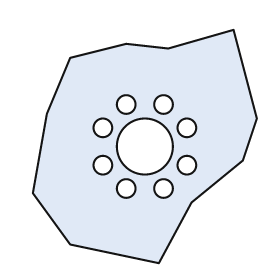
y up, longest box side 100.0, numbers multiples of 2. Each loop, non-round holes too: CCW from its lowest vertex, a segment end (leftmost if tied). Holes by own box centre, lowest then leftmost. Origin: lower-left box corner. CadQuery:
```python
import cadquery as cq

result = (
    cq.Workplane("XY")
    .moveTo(54.0, 0.0)
    .lineTo(68.0, 26.0)
    .lineTo(90.0, 44.0)
    .lineTo(96.0, 62.0)
    .lineTo(86.0, 100.0)
    .lineTo(58.0, 92.0)
    .lineTo(40.0, 94.0)
    .lineTo(16.0, 88.0)
    .lineTo(6.0, 64.0)
    .lineTo(0.0, 30.0)
    .lineTo(16.0, 8.0)
    .close()
    .moveTo(40.0, 32.0)
    .circle(4.0)
    .moveTo(56.0, 32.0)
    .circle(4.0)
    .moveTo(30.0, 42.0)
    .circle(4.0)
    .moveTo(66.0, 42.0)
    .circle(4.0)
    .moveTo(48.0, 50.0)
    .circle(12.0)
    .moveTo(30.0, 58.0)
    .circle(4.0)
    .moveTo(66.0, 58.0)
    .circle(4.0)
    .moveTo(40.0, 68.0)
    .circle(4.0)
    .moveTo(56.0, 68.0)
    .circle(4.0)
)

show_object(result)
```